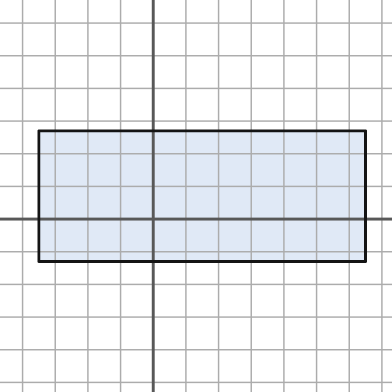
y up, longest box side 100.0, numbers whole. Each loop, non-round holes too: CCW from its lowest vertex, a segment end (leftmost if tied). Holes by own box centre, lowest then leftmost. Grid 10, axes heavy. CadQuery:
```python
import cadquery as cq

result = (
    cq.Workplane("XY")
    .moveTo(-35.0, -13.0)
    .lineTo(65.0, -13.0)
    .lineTo(65.0, 27.0)
    .lineTo(-35.0, 27.0)
    .close()
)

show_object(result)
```